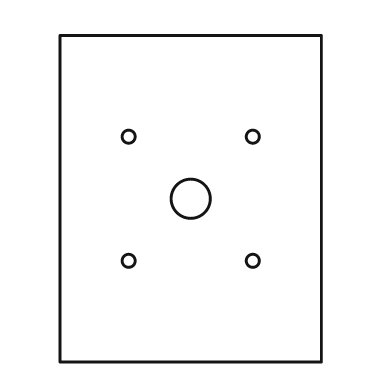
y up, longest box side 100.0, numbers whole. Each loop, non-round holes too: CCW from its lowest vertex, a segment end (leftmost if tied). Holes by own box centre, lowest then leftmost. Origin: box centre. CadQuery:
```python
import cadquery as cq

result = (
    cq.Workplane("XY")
    .moveTo(-40.0, -50.0)
    .lineTo(40.0, -50.0)
    .lineTo(40.0, 50.0)
    .lineTo(-40.0, 50.0)
    .close()
    .moveTo(-19.0, -19.0)
    .circle(2.0)
    .moveTo(19.0, -19.0)
    .circle(2.0)
    .moveTo(0.0, 0.0)
    .circle(6.0)
    .moveTo(-19.0, 19.0)
    .circle(2.0)
    .moveTo(19.0, 19.0)
    .circle(2.0)
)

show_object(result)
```